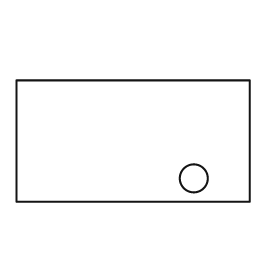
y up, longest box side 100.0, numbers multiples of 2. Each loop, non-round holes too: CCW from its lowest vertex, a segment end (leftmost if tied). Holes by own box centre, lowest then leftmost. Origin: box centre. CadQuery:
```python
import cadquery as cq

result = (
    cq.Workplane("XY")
    .moveTo(-50.0, -26.0)
    .lineTo(50.0, -26.0)
    .lineTo(50.0, 26.0)
    .lineTo(-50.0, 26.0)
    .close()
    .moveTo(26.0, -16.0)
    .circle(6.0)
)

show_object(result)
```